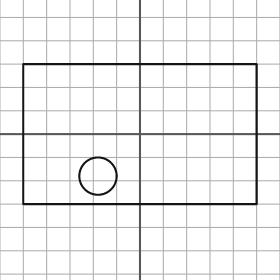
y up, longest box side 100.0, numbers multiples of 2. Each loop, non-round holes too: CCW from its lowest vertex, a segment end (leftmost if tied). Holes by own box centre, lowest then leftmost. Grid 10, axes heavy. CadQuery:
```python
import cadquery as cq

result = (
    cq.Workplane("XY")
    .moveTo(-50.0, -30.0)
    .lineTo(50.0, -30.0)
    .lineTo(50.0, 30.0)
    .lineTo(-50.0, 30.0)
    .close()
    .moveTo(-18.0, -18.0)
    .circle(8.0)
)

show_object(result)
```